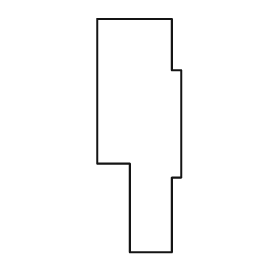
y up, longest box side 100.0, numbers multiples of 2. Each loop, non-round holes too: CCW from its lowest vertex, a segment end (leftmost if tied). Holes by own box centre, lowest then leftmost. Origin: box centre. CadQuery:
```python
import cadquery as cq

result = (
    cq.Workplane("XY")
    .moveTo(-4.0, -50.0)
    .lineTo(14.0, -50.0)
    .lineTo(14.0, -18.0)
    .lineTo(18.0, -18.0)
    .lineTo(18.0, 28.0)
    .lineTo(14.0, 28.0)
    .lineTo(14.0, 50.0)
    .lineTo(-18.0, 50.0)
    .lineTo(-18.0, -12.0)
    .lineTo(-4.0, -12.0)
    .close()
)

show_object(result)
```